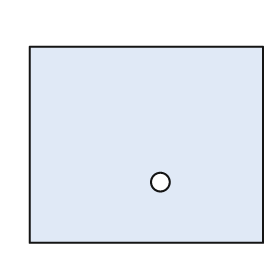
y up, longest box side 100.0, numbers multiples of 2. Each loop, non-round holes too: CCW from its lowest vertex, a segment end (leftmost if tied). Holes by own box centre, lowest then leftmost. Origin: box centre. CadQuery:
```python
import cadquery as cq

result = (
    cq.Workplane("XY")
    .moveTo(-50.0, -42.0)
    .lineTo(50.0, -42.0)
    .lineTo(50.0, 42.0)
    .lineTo(-50.0, 42.0)
    .close()
    .moveTo(6.0, -16.0)
    .circle(4.0)
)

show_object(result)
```